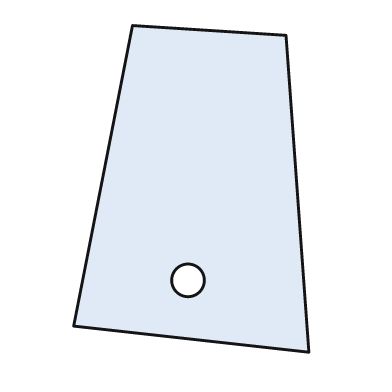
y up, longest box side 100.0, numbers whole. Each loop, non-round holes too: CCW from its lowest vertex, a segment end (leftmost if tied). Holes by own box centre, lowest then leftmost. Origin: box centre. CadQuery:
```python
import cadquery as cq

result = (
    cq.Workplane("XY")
    .moveTo(36.0, -50.0)
    .lineTo(29.0, 47.0)
    .lineTo(-18.0, 50.0)
    .lineTo(-36.0, -42.0)
    .close()
    .moveTo(-1.0, -28.0)
    .circle(5.0)
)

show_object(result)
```